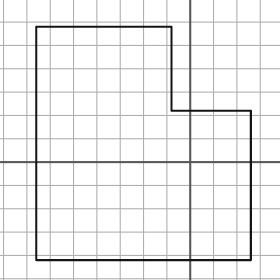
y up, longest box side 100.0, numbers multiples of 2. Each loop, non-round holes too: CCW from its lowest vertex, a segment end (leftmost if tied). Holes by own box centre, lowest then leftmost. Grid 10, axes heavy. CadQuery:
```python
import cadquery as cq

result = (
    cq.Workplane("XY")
    .moveTo(-66.0, -42.0)
    .lineTo(26.0, -42.0)
    .lineTo(26.0, 22.0)
    .lineTo(-8.0, 22.0)
    .lineTo(-8.0, 58.0)
    .lineTo(-66.0, 58.0)
    .close()
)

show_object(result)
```